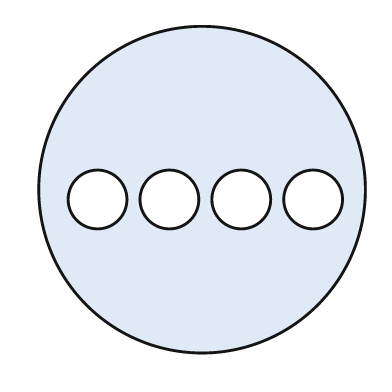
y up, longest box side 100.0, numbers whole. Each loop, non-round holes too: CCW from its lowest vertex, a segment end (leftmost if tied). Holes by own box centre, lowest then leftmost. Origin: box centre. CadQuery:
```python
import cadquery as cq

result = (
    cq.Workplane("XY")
    .moveTo(0.0, 0.0)
    .circle(50.0)
    .moveTo(-32.0, -3.0)
    .circle(9.0)
    .moveTo(-10.0, -3.0)
    .circle(9.0)
    .moveTo(12.0, -3.0)
    .circle(9.0)
    .moveTo(34.0, -3.0)
    .circle(9.0)
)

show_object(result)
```